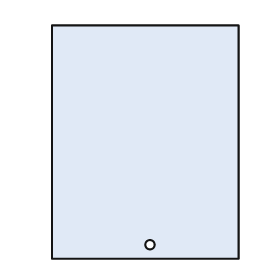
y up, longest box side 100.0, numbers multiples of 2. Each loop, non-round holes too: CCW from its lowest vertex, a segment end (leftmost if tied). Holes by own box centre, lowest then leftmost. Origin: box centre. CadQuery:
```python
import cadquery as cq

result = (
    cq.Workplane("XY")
    .moveTo(-40.0, -50.0)
    .lineTo(40.0, -50.0)
    .lineTo(40.0, 50.0)
    .lineTo(-40.0, 50.0)
    .close()
    .moveTo(2.0, -44.0)
    .circle(2.0)
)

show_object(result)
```